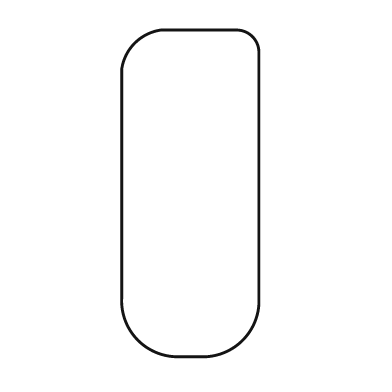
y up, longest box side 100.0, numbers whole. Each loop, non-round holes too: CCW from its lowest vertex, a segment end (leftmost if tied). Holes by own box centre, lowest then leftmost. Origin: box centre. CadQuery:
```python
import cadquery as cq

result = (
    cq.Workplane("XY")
    .moveTo(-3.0, -50.0)
    .lineTo(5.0, -50.0)
    .threePointArc((16.0, -45.0), (21.0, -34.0))
    .lineTo(21.0, 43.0)
    .threePointArc((19.0, 48.0), (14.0, 50.0))
    .lineTo(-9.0, 50.0)
    .threePointArc((-17.0, 46.0), (-21.0, 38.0))
    .lineTo(-21.0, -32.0)
    .threePointArc((-16.0, -45.0), (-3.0, -50.0))
    .close()
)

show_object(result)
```